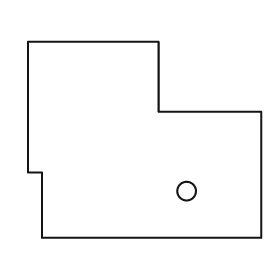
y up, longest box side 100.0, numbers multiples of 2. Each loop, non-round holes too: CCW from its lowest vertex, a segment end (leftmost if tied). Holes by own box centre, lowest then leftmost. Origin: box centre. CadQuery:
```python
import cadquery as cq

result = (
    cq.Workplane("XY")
    .moveTo(-44.0, -42.0)
    .lineTo(50.0, -42.0)
    .lineTo(50.0, 12.0)
    .lineTo(6.0, 12.0)
    .lineTo(6.0, 42.0)
    .lineTo(-50.0, 42.0)
    .lineTo(-50.0, -14.0)
    .lineTo(-44.0, -14.0)
    .close()
    .moveTo(18.0, -22.0)
    .circle(4.0)
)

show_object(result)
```